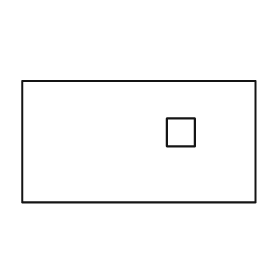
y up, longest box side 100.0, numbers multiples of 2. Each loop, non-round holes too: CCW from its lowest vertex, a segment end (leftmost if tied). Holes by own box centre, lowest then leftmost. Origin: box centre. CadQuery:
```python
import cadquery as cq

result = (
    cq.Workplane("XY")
    .moveTo(-50.0, -26.0)
    .lineTo(50.0, -26.0)
    .lineTo(50.0, 26.0)
    .lineTo(-50.0, 26.0)
    .close()
    .moveTo(12.0, -2.0)
    .lineTo(24.0, -2.0)
    .lineTo(24.0, 10.0)
    .lineTo(12.0, 10.0)
    .close()
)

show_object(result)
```